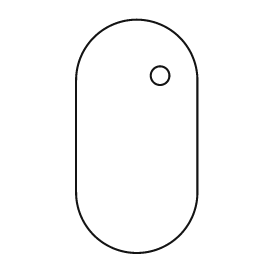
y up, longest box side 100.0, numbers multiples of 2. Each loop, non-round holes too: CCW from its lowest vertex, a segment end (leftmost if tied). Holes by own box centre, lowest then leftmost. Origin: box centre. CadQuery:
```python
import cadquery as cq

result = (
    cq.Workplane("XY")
    .moveTo(-26.0, -24.0)
    .threePointArc((0.0, -50.0), (26.0, -24.0))
    .lineTo(26.0, 24.0)
    .threePointArc((0.0, 50.0), (-26.0, 24.0))
    .close()
    .moveTo(10.0, 26.0)
    .circle(4.0)
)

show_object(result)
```